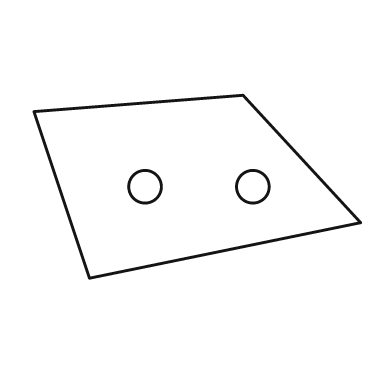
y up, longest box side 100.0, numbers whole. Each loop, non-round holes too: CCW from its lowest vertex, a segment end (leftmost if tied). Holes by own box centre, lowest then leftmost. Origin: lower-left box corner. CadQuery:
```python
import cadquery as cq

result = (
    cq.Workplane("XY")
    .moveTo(17.0, 0.0)
    .lineTo(100.0, 17.0)
    .lineTo(64.0, 56.0)
    .lineTo(0.0, 51.0)
    .close()
    .moveTo(34.0, 28.0)
    .circle(5.0)
    .moveTo(67.0, 28.0)
    .circle(5.0)
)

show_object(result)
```